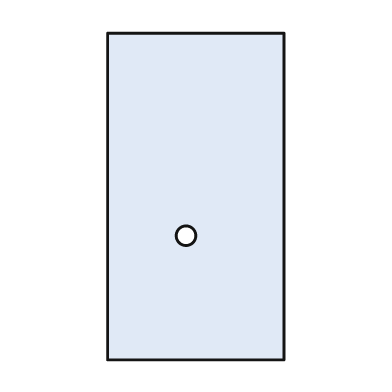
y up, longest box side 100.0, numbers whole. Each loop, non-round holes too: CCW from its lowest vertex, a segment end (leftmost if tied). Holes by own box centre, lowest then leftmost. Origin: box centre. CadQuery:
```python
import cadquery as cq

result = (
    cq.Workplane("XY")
    .moveTo(-27.0, -50.0)
    .lineTo(27.0, -50.0)
    .lineTo(27.0, 50.0)
    .lineTo(-27.0, 50.0)
    .close()
    .moveTo(-3.0, -12.0)
    .circle(3.0)
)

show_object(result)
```